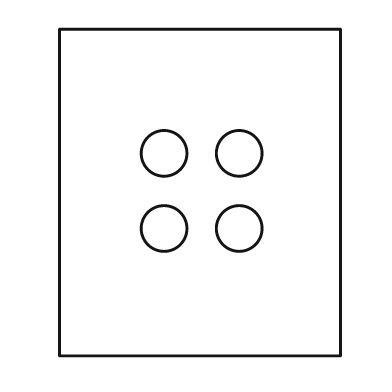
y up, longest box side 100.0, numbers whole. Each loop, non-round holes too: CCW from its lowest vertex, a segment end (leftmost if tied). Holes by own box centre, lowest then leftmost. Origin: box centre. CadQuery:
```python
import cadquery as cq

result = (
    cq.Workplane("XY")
    .moveTo(-43.0, -50.0)
    .lineTo(43.0, -50.0)
    .lineTo(43.0, 50.0)
    .lineTo(-43.0, 50.0)
    .close()
    .moveTo(-11.0, -11.0)
    .circle(7.0)
    .moveTo(12.0, -11.0)
    .circle(7.0)
    .moveTo(-11.0, 12.0)
    .circle(7.0)
    .moveTo(12.0, 12.0)
    .circle(7.0)
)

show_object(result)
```